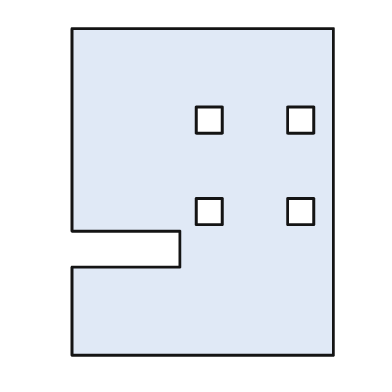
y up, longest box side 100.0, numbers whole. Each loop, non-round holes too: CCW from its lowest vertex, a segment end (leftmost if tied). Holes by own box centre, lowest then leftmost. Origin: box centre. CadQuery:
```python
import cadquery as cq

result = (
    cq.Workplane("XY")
    .moveTo(-40.0, -50.0)
    .lineTo(40.0, -50.0)
    .lineTo(40.0, 50.0)
    .lineTo(-40.0, 50.0)
    .lineTo(-40.0, -12.0)
    .lineTo(-7.0, -12.0)
    .lineTo(-7.0, -23.0)
    .lineTo(-40.0, -23.0)
    .close()
    .moveTo(-2.0, -10.0)
    .lineTo(6.0, -10.0)
    .lineTo(6.0, -2.0)
    .lineTo(-2.0, -2.0)
    .close()
    .moveTo(26.0, -10.0)
    .lineTo(34.0, -10.0)
    .lineTo(34.0, -2.0)
    .lineTo(26.0, -2.0)
    .close()
    .moveTo(-2.0, 18.0)
    .lineTo(6.0, 18.0)
    .lineTo(6.0, 26.0)
    .lineTo(-2.0, 26.0)
    .close()
    .moveTo(26.0, 18.0)
    .lineTo(34.0, 18.0)
    .lineTo(34.0, 26.0)
    .lineTo(26.0, 26.0)
    .close()
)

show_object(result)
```